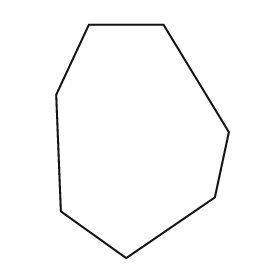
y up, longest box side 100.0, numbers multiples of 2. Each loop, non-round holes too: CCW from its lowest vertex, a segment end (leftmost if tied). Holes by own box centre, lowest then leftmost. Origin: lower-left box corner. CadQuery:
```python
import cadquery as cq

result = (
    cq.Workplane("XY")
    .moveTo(30.0, 0.0)
    .lineTo(68.0, 26.0)
    .lineTo(74.0, 54.0)
    .lineTo(46.0, 100.0)
    .lineTo(14.0, 100.0)
    .lineTo(0.0, 70.0)
    .lineTo(2.0, 20.0)
    .close()
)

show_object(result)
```